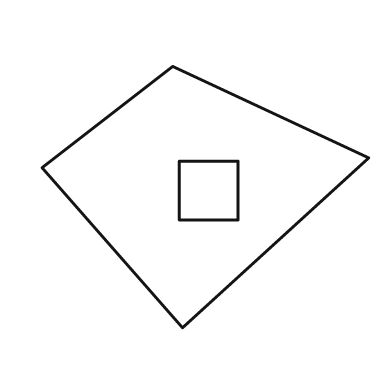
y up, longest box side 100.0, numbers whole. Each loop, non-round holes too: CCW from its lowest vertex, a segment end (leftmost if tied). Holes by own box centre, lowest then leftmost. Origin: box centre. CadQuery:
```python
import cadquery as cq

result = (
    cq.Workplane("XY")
    .moveTo(-7.0, -40.0)
    .lineTo(50.0, 12.0)
    .lineTo(-10.0, 40.0)
    .lineTo(-50.0, 9.0)
    .close()
    .moveTo(-8.0, -7.0)
    .lineTo(10.0, -7.0)
    .lineTo(10.0, 11.0)
    .lineTo(-8.0, 11.0)
    .close()
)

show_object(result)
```